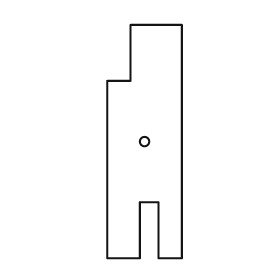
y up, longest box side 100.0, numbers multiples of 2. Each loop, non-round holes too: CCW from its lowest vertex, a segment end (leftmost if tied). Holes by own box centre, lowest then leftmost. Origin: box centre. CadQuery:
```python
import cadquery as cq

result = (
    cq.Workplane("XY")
    .moveTo(-16.0, -50.0)
    .lineTo(-2.0, -50.0)
    .lineTo(-2.0, -26.0)
    .lineTo(6.0, -26.0)
    .lineTo(6.0, -50.0)
    .lineTo(16.0, -50.0)
    .lineTo(16.0, 50.0)
    .lineTo(-6.0, 50.0)
    .lineTo(-6.0, 26.0)
    .lineTo(-16.0, 26.0)
    .close()
    .moveTo(0.0, 0.0)
    .circle(2.0)
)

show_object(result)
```